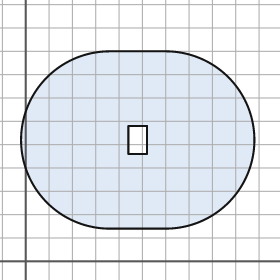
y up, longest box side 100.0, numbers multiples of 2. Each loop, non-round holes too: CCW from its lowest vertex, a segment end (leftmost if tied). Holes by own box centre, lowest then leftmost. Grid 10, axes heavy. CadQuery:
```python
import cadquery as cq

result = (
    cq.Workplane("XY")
    .moveTo(36.0, 14.0)
    .lineTo(60.0, 14.0)
    .threePointArc((98.0, 52.0), (60.0, 90.0))
    .lineTo(36.0, 90.0)
    .threePointArc((-2.0, 52.0), (36.0, 14.0))
    .close()
    .moveTo(44.0, 46.0)
    .lineTo(52.0, 46.0)
    .lineTo(52.0, 58.0)
    .lineTo(44.0, 58.0)
    .close()
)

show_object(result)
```